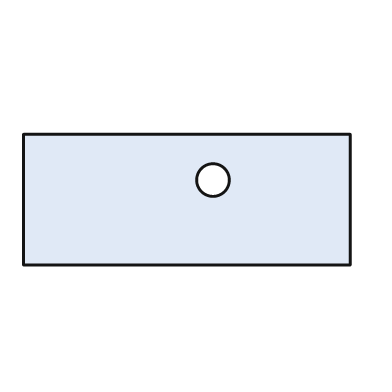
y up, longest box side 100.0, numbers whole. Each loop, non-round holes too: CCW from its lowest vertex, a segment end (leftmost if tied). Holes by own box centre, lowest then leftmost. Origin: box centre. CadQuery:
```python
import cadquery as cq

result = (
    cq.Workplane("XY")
    .moveTo(-50.0, -20.0)
    .lineTo(50.0, -20.0)
    .lineTo(50.0, 20.0)
    .lineTo(-50.0, 20.0)
    .close()
    .moveTo(8.0, 6.0)
    .circle(5.0)
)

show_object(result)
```